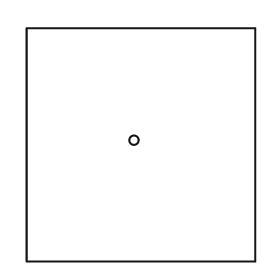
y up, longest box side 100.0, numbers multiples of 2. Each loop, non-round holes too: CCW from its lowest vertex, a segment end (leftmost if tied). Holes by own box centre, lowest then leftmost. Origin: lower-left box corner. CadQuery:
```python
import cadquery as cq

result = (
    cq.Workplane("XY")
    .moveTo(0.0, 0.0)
    .lineTo(98.0, 0.0)
    .lineTo(98.0, 100.0)
    .lineTo(0.0, 100.0)
    .close()
    .moveTo(46.0, 52.0)
    .circle(2.0)
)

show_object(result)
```